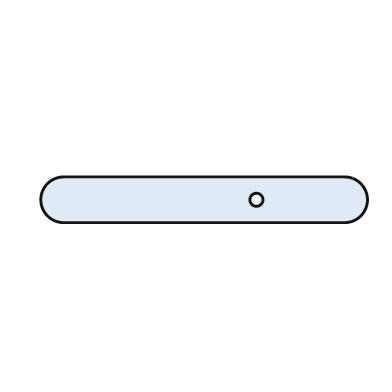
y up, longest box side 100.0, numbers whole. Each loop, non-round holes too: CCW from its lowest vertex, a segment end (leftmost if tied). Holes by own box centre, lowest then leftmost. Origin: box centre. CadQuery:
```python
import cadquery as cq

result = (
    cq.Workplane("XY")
    .moveTo(-43.0, -7.0)
    .lineTo(43.0, -7.0)
    .threePointArc((50.0, 0.0), (43.0, 7.0))
    .lineTo(-43.0, 7.0)
    .threePointArc((-50.0, 0.0), (-43.0, -7.0))
    .close()
    .moveTo(16.0, 0.0)
    .circle(2.0)
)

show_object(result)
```